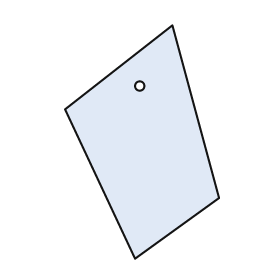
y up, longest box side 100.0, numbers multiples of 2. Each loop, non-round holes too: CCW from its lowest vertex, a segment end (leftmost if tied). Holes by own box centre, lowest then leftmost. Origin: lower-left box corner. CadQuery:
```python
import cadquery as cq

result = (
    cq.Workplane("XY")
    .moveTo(30.0, 0.0)
    .lineTo(66.0, 26.0)
    .lineTo(46.0, 100.0)
    .lineTo(0.0, 64.0)
    .close()
    .moveTo(32.0, 74.0)
    .circle(2.0)
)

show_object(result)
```